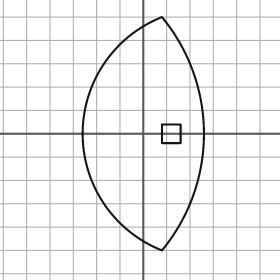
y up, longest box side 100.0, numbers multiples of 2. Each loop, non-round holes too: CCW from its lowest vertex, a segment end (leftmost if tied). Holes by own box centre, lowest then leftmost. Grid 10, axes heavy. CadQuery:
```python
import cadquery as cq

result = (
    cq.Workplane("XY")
    .moveTo(8.0, -50.0)
    .threePointArc((26.0, 0.0), (8.0, 50.0))
    .threePointArc((-26.0, 0.0), (8.0, -50.0))
    .close()
    .moveTo(8.0, -4.0)
    .lineTo(16.0, -4.0)
    .lineTo(16.0, 4.0)
    .lineTo(8.0, 4.0)
    .close()
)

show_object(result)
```